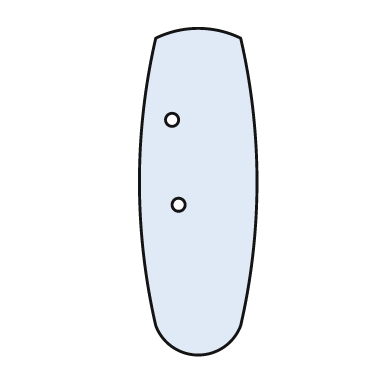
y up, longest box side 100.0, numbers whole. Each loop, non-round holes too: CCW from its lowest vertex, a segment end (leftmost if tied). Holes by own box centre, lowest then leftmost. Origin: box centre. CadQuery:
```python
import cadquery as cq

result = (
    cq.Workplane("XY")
    .moveTo(-13.0, -41.0)
    .threePointArc((0.0, -50.0), (13.0, -41.0))
    .threePointArc((18.0, 3.0), (13.0, 47.0))
    .threePointArc((0.0, 50.0), (-13.0, 47.0))
    .threePointArc((-18.0, 3.0), (-13.0, -41.0))
    .close()
    .moveTo(-6.0, -4.0)
    .circle(2.0)
    .moveTo(-8.0, 22.0)
    .circle(2.0)
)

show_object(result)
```